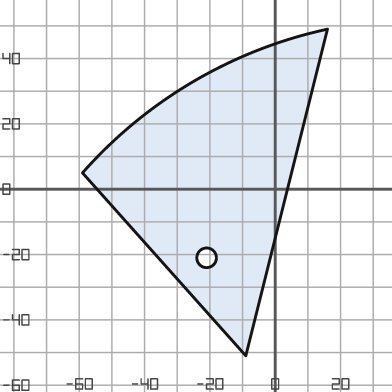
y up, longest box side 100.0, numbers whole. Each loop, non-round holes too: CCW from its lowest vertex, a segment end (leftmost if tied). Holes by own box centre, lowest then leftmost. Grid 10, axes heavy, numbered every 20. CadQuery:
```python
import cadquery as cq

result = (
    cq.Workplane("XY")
    .moveTo(-9.0, -51.0)
    .lineTo(16.0, 49.0)
    .threePointArc((-25.0, 33.0), (-59.0, 5.0))
    .close()
    .moveTo(-21.0, -21.0)
    .circle(3.0)
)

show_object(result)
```